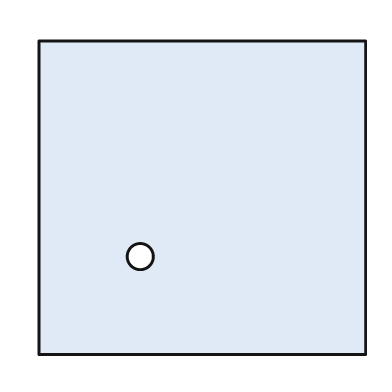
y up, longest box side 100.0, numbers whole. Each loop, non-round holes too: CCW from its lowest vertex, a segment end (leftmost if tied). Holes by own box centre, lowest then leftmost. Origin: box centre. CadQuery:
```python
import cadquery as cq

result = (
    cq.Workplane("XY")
    .moveTo(-50.0, -48.0)
    .lineTo(50.0, -48.0)
    .lineTo(50.0, 48.0)
    .lineTo(-50.0, 48.0)
    .close()
    .moveTo(-19.0, -18.0)
    .circle(4.0)
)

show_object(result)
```